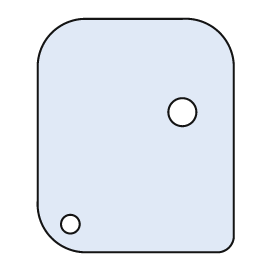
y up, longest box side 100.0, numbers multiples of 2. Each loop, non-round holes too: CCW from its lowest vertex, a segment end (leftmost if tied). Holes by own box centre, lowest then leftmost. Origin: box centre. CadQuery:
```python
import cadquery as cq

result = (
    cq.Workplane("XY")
    .moveTo(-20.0, -50.0)
    .lineTo(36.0, -50.0)
    .threePointArc((40.0, -48.0), (42.0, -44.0))
    .lineTo(42.0, 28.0)
    .threePointArc((36.0, 44.0), (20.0, 50.0))
    .lineTo(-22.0, 50.0)
    .threePointArc((-36.0, 44.0), (-42.0, 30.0))
    .lineTo(-42.0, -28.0)
    .threePointArc((-36.0, -44.0), (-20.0, -50.0))
    .close()
    .moveTo(-28.0, -38.0)
    .circle(4.0)
    .moveTo(20.0, 10.0)
    .circle(6.0)
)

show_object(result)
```